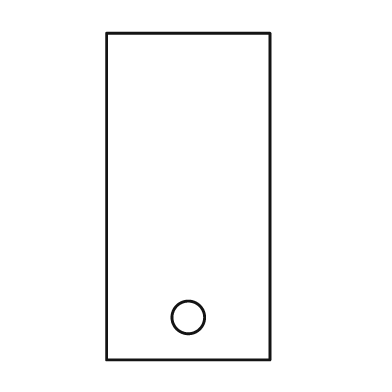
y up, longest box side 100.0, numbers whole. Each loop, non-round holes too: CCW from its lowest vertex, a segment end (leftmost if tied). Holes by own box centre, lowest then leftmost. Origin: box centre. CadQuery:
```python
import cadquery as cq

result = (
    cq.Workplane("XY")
    .moveTo(-25.0, -50.0)
    .lineTo(25.0, -50.0)
    .lineTo(25.0, 50.0)
    .lineTo(-25.0, 50.0)
    .close()
    .moveTo(0.0, -37.0)
    .circle(5.0)
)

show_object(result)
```